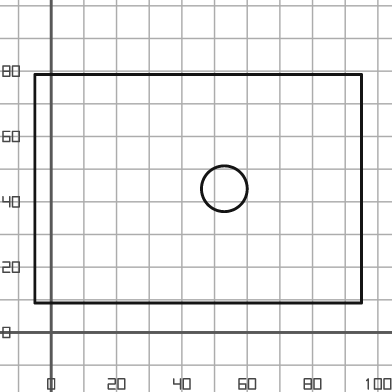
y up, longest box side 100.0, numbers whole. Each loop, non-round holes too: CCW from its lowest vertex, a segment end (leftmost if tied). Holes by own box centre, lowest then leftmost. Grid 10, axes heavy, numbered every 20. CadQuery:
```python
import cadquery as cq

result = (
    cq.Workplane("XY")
    .moveTo(-5.0, 9.0)
    .lineTo(95.0, 9.0)
    .lineTo(95.0, 79.0)
    .lineTo(-5.0, 79.0)
    .close()
    .moveTo(53.0, 44.0)
    .circle(7.0)
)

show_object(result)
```